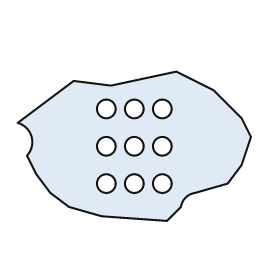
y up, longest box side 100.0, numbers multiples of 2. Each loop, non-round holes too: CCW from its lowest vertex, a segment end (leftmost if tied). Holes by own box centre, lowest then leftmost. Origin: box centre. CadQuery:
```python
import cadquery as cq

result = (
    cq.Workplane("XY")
    .moveTo(14.0, -32.0)
    .lineTo(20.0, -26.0)
    .threePointArc((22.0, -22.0), (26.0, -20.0))
    .lineTo(40.0, -16.0)
    .lineTo(46.0, -8.0)
    .lineTo(50.0, 4.0)
    .lineTo(46.0, 12.0)
    .lineTo(34.0, 24.0)
    .lineTo(18.0, 32.0)
    .lineTo(-10.0, 26.0)
    .lineTo(-26.0, 28.0)
    .lineTo(-50.0, 10.0)
    .threePointArc((-44.0, 4.0), (-46.0, -4.0))
    .lineTo(-42.0, -12.0)
    .lineTo(-36.0, -20.0)
    .lineTo(-28.0, -26.0)
    .lineTo(-14.0, -30.0)
    .close()
    .moveTo(-12.0, -16.0)
    .circle(4.0)
    .moveTo(0.0, -16.0)
    .circle(4.0)
    .moveTo(12.0, -16.0)
    .circle(4.0)
    .moveTo(-12.0, 0.0)
    .circle(4.0)
    .moveTo(0.0, 0.0)
    .circle(4.0)
    .moveTo(12.0, 0.0)
    .circle(4.0)
    .moveTo(-12.0, 16.0)
    .circle(4.0)
    .moveTo(0.0, 16.0)
    .circle(4.0)
    .moveTo(12.0, 16.0)
    .circle(4.0)
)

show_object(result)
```